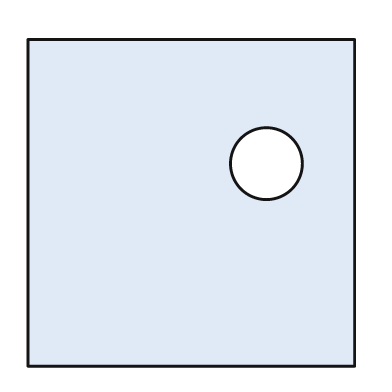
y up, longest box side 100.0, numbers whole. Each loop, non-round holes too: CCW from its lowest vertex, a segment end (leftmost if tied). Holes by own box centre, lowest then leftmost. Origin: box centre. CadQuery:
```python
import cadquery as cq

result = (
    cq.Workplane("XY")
    .moveTo(-50.0, -50.0)
    .lineTo(50.0, -50.0)
    .lineTo(50.0, 50.0)
    .lineTo(-50.0, 50.0)
    .close()
    .moveTo(23.0, 12.0)
    .circle(11.0)
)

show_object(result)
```